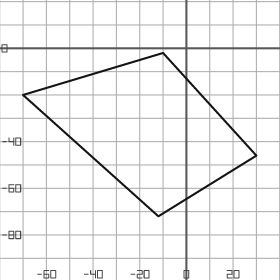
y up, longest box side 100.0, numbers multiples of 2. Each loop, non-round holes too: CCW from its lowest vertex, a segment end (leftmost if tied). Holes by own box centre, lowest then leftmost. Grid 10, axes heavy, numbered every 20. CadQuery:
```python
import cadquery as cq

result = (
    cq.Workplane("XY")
    .moveTo(-12.0, -72.0)
    .lineTo(30.0, -46.0)
    .lineTo(-10.0, -2.0)
    .lineTo(-70.0, -20.0)
    .close()
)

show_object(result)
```